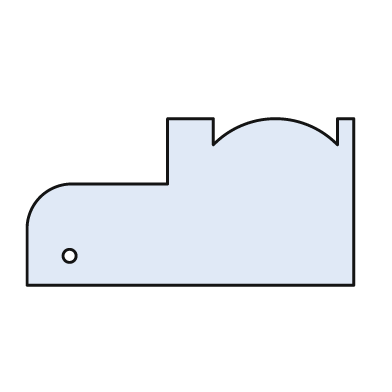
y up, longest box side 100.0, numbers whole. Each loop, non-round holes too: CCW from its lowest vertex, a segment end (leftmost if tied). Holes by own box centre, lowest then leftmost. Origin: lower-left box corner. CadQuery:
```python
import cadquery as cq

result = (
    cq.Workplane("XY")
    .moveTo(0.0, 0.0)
    .lineTo(100.0, 0.0)
    .lineTo(100.0, 51.0)
    .lineTo(95.0, 51.0)
    .lineTo(95.0, 43.0)
    .threePointArc((76.0, 51.0), (57.0, 43.0))
    .lineTo(57.0, 51.0)
    .lineTo(43.0, 51.0)
    .lineTo(43.0, 31.0)
    .lineTo(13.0, 31.0)
    .threePointArc((4.0, 27.0), (0.0, 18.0))
    .close()
    .moveTo(13.0, 9.0)
    .circle(2.0)
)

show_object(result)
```